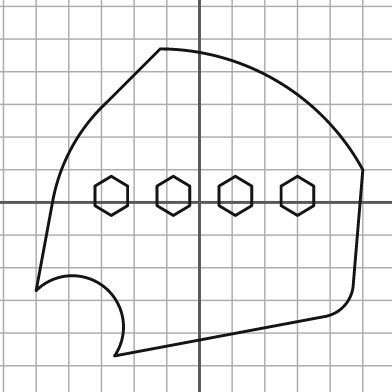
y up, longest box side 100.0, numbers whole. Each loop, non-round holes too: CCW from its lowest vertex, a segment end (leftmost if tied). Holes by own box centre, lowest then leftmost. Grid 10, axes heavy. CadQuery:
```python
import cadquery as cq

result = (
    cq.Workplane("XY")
    .moveTo(-26.0, -47.0)
    .lineTo(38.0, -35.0)
    .threePointArc((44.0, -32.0), (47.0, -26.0))
    .lineTo(50.0, 10.0)
    .threePointArc((24.0, 37.0), (-12.0, 47.0))
    .lineTo(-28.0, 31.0)
    .threePointArc((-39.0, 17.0), (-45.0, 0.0))
    .lineTo(-50.0, -27.0)
    .threePointArc((-29.0, -26.0), (-26.0, -47.0))
    .close()
    .moveTo(-27.0, -4.0)
    .lineTo(-22.0, -1.0)
    .lineTo(-22.0, 5.0)
    .lineTo(-27.0, 8.0)
    .lineTo(-32.0, 5.0)
    .lineTo(-32.0, -1.0)
    .close()
    .moveTo(-8.0, -4.0)
    .lineTo(-3.0, -1.0)
    .lineTo(-3.0, 5.0)
    .lineTo(-8.0, 8.0)
    .lineTo(-13.0, 5.0)
    .lineTo(-13.0, -1.0)
    .close()
    .moveTo(11.0, -4.0)
    .lineTo(16.0, -1.0)
    .lineTo(16.0, 5.0)
    .lineTo(11.0, 8.0)
    .lineTo(6.0, 5.0)
    .lineTo(6.0, -1.0)
    .close()
    .moveTo(30.0, -4.0)
    .lineTo(35.0, -1.0)
    .lineTo(35.0, 5.0)
    .lineTo(30.0, 8.0)
    .lineTo(25.0, 5.0)
    .lineTo(25.0, -1.0)
    .close()
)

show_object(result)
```